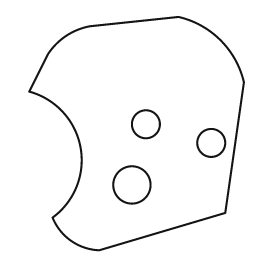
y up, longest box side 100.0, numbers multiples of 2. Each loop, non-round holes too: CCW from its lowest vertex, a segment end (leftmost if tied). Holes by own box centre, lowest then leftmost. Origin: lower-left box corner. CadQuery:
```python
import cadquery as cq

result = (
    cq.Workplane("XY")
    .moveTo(30.0, 0.0)
    .lineTo(84.0, 16.0)
    .lineTo(92.0, 72.0)
    .threePointArc((82.0, 90.0), (64.0, 100.0))
    .lineTo(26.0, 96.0)
    .threePointArc((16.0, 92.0), (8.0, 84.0))
    .lineTo(0.0, 68.0)
    .threePointArc((22.0, 44.0), (10.0, 14.0))
    .threePointArc((18.0, 4.0), (30.0, 0.0))
    .close()
    .moveTo(44.0, 28.0)
    .circle(8.0)
    .moveTo(78.0, 46.0)
    .circle(6.0)
    .moveTo(50.0, 54.0)
    .circle(6.0)
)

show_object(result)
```